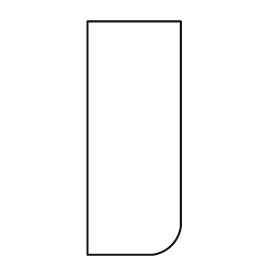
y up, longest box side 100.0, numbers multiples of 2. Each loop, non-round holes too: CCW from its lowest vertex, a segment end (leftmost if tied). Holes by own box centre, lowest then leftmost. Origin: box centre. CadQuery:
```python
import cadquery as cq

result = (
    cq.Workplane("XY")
    .moveTo(-20.0, -50.0)
    .lineTo(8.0, -50.0)
    .threePointArc((16.0, -46.0), (20.0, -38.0))
    .lineTo(20.0, 50.0)
    .lineTo(-20.0, 50.0)
    .close()
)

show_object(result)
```